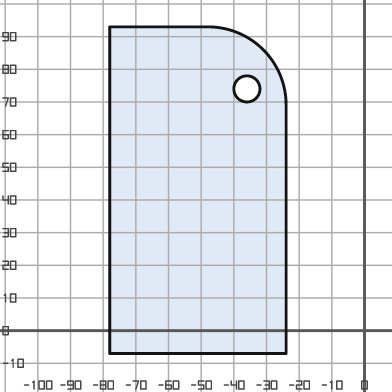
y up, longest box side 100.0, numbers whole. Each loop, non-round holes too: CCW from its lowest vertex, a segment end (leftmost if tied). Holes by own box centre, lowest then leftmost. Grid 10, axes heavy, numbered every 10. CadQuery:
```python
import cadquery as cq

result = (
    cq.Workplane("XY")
    .moveTo(-78.0, -7.0)
    .lineTo(-24.0, -7.0)
    .lineTo(-24.0, 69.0)
    .threePointArc((-31.0, 86.0), (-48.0, 93.0))
    .lineTo(-78.0, 93.0)
    .close()
    .moveTo(-36.0, 74.0)
    .circle(4.0)
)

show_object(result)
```